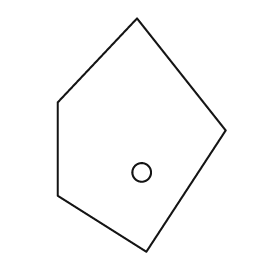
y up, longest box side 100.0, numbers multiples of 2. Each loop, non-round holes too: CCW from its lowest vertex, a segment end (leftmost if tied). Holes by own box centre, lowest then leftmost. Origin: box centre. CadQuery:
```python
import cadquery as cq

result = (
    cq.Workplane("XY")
    .moveTo(2.0, -50.0)
    .lineTo(36.0, 2.0)
    .lineTo(-2.0, 50.0)
    .lineTo(-36.0, 14.0)
    .lineTo(-36.0, -26.0)
    .close()
    .moveTo(0.0, -16.0)
    .circle(4.0)
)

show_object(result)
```